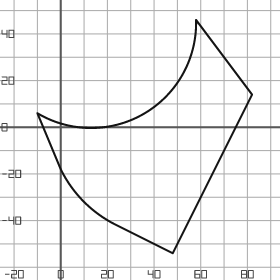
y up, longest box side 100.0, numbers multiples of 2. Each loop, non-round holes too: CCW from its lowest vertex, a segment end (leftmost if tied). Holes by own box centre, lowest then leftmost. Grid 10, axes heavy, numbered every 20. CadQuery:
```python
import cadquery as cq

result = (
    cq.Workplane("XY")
    .moveTo(48.0, -54.0)
    .lineTo(82.0, 14.0)
    .lineTo(58.0, 46.0)
    .threePointArc((36.0, 6.0), (-10.0, 6.0))
    .lineTo(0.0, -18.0)
    .threePointArc((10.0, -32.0), (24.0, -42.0))
    .close()
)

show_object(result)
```